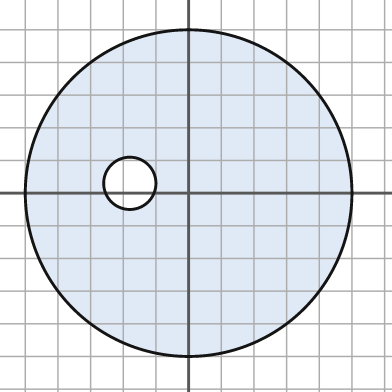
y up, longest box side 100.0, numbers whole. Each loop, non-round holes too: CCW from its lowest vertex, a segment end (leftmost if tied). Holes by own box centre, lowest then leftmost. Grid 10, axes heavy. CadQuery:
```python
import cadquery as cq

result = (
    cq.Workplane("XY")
    .moveTo(0.0, 0.0)
    .circle(50.0)
    .moveTo(-18.0, 3.0)
    .circle(8.0)
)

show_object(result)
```